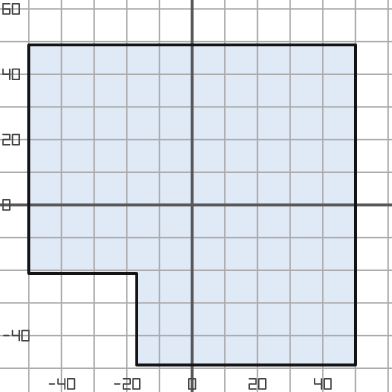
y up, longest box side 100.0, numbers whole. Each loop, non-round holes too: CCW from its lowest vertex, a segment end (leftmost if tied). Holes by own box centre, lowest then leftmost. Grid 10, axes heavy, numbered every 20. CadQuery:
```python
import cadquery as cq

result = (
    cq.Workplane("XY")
    .moveTo(-17.0, -49.0)
    .lineTo(50.0, -49.0)
    .lineTo(50.0, 49.0)
    .lineTo(-50.0, 49.0)
    .lineTo(-50.0, -21.0)
    .lineTo(-17.0, -21.0)
    .close()
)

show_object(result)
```